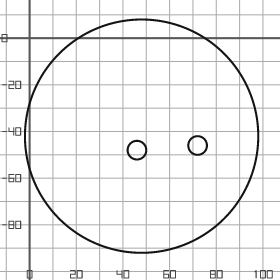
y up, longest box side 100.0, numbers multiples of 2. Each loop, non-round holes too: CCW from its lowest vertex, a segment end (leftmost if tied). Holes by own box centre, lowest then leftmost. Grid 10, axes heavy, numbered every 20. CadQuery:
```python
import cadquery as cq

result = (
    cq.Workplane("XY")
    .moveTo(48.0, -42.0)
    .circle(50.0)
    .moveTo(46.0, -48.0)
    .circle(4.0)
    .moveTo(72.0, -46.0)
    .circle(4.0)
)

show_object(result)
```